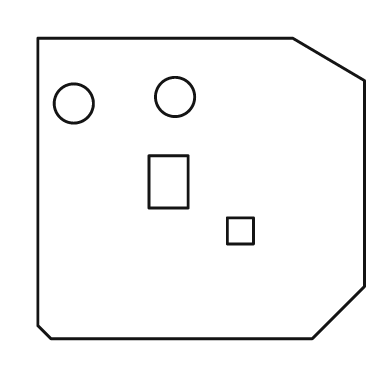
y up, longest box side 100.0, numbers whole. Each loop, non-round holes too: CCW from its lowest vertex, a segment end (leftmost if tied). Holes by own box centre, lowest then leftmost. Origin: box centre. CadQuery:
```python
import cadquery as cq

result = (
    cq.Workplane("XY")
    .moveTo(-46.0, -46.0)
    .lineTo(34.0, -46.0)
    .lineTo(50.0, -30.0)
    .lineTo(50.0, 33.0)
    .lineTo(28.0, 46.0)
    .lineTo(-50.0, 46.0)
    .lineTo(-50.0, -42.0)
    .close()
    .moveTo(8.0, -17.0)
    .lineTo(16.0, -17.0)
    .lineTo(16.0, -9.0)
    .lineTo(8.0, -9.0)
    .close()
    .moveTo(-16.0, -6.0)
    .lineTo(-4.0, -6.0)
    .lineTo(-4.0, 10.0)
    .lineTo(-16.0, 10.0)
    .close()
    .moveTo(-39.0, 26.0)
    .circle(6.0)
    .moveTo(-8.0, 28.0)
    .circle(6.0)
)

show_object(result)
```